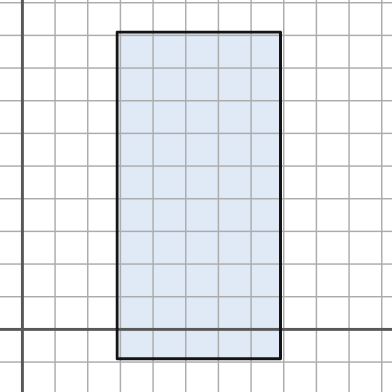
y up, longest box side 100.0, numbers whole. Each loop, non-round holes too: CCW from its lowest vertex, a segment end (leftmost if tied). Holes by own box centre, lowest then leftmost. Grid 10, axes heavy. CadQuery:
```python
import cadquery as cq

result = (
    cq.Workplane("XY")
    .moveTo(29.0, -9.0)
    .lineTo(79.0, -9.0)
    .lineTo(79.0, 91.0)
    .lineTo(29.0, 91.0)
    .close()
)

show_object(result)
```